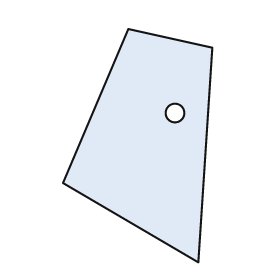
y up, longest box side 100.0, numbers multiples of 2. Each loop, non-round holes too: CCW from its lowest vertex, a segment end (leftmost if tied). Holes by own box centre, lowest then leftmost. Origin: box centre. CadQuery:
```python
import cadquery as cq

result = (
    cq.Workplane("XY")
    .moveTo(26.0, -50.0)
    .lineTo(32.0, 42.0)
    .lineTo(-4.0, 50.0)
    .lineTo(-32.0, -16.0)
    .close()
    .moveTo(16.0, 14.0)
    .circle(4.0)
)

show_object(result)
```